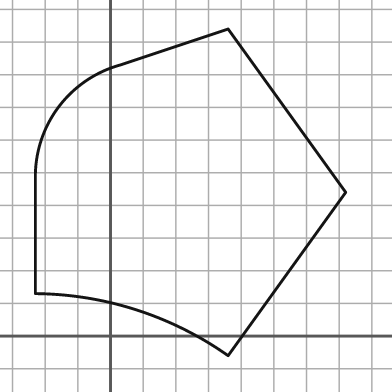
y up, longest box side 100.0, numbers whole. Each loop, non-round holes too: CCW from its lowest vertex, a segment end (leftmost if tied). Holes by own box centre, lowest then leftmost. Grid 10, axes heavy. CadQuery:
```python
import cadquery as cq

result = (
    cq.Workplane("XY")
    .moveTo(36.0, -6.0)
    .lineTo(72.0, 44.0)
    .lineTo(36.0, 94.0)
    .lineTo(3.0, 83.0)
    .threePointArc((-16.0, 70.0), (-23.0, 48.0))
    .lineTo(-23.0, 13.0)
    .threePointArc((8.0, 8.0), (36.0, -6.0))
    .close()
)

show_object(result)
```